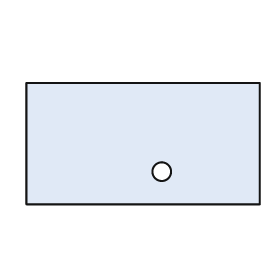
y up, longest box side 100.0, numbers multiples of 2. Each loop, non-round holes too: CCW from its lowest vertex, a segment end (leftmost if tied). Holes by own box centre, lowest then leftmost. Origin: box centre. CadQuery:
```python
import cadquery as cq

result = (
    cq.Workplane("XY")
    .moveTo(-50.0, -26.0)
    .lineTo(50.0, -26.0)
    .lineTo(50.0, 26.0)
    .lineTo(-50.0, 26.0)
    .close()
    .moveTo(8.0, -12.0)
    .circle(4.0)
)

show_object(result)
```